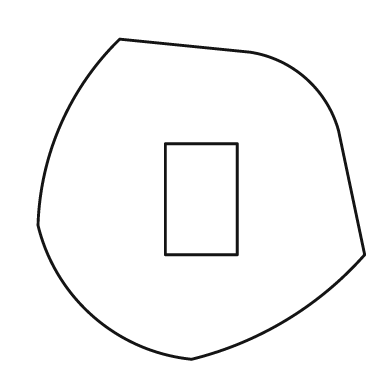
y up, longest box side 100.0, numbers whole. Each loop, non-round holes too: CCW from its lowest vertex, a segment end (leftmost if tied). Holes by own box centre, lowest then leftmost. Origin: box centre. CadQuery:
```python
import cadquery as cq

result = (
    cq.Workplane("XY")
    .moveTo(-3.0, -49.0)
    .threePointArc((26.0, -37.0), (50.0, -17.0))
    .lineTo(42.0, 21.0)
    .threePointArc((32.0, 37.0), (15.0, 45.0))
    .lineTo(-25.0, 49.0)
    .threePointArc((-43.0, 23.0), (-50.0, -8.0))
    .threePointArc((-33.0, -36.0), (-3.0, -49.0))
    .close()
    .moveTo(-11.0, -17.0)
    .lineTo(11.0, -17.0)
    .lineTo(11.0, 17.0)
    .lineTo(-11.0, 17.0)
    .close()
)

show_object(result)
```